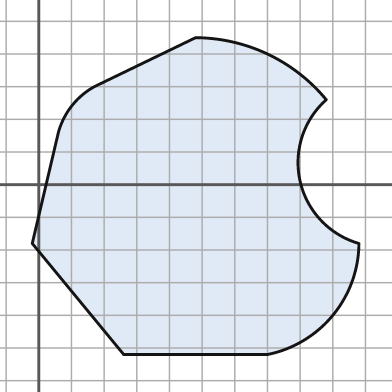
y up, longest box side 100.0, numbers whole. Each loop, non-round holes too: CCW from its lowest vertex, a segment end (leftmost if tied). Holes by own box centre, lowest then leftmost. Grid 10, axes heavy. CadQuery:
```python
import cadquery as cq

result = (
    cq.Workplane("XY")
    .moveTo(26.0, -52.0)
    .lineTo(70.0, -52.0)
    .threePointArc((90.0, -40.0), (98.0, -18.0))
    .threePointArc((80.0, 1.0), (88.0, 26.0))
    .threePointArc((70.0, 40.0), (48.0, 45.0))
    .lineTo(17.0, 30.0)
    .threePointArc((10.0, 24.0), (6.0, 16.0))
    .lineTo(-2.0, -18.0)
    .close()
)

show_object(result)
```